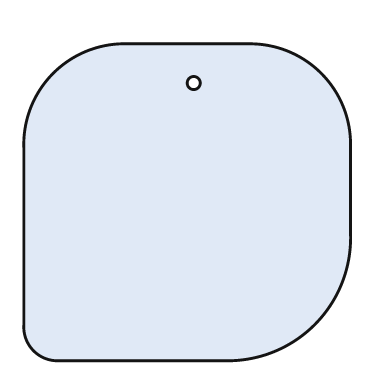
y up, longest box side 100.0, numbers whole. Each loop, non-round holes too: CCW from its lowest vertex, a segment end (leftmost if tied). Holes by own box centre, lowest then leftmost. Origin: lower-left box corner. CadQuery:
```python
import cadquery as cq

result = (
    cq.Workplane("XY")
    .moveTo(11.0, 0.0)
    .lineTo(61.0, 0.0)
    .threePointArc((89.0, 11.0), (100.0, 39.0))
    .lineTo(100.0, 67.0)
    .threePointArc((91.0, 88.0), (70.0, 97.0))
    .lineTo(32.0, 97.0)
    .threePointArc((9.0, 88.0), (0.0, 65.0))
    .lineTo(0.0, 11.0)
    .threePointArc((3.0, 3.0), (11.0, 0.0))
    .close()
    .moveTo(52.0, 85.0)
    .circle(2.0)
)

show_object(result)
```